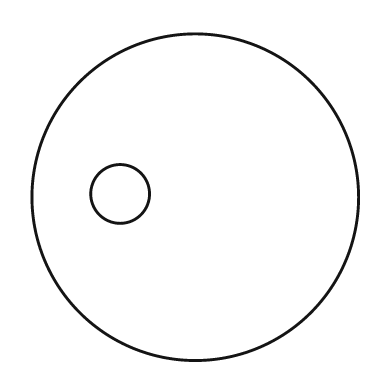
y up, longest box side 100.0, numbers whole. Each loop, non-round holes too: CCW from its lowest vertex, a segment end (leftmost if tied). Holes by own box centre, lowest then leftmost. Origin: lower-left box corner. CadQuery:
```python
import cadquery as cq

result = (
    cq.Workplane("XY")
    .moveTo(50.0, 50.0)
    .circle(50.0)
    .moveTo(27.0, 51.0)
    .circle(9.0)
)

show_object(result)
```